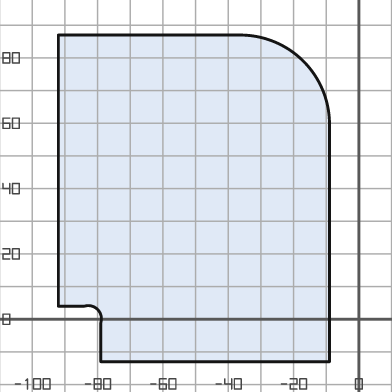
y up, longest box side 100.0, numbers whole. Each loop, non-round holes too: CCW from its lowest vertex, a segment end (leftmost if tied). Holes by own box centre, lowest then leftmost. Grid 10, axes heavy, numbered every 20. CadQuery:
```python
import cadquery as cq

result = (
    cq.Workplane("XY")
    .moveTo(-79.0, -13.0)
    .lineTo(-9.0, -13.0)
    .lineTo(-9.0, 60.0)
    .threePointArc((-17.0, 79.0), (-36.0, 87.0))
    .lineTo(-92.0, 87.0)
    .lineTo(-92.0, 4.0)
    .lineTo(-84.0, 4.0)
    .threePointArc((-80.0, 3.0), (-79.0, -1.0))
    .close()
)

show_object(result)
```